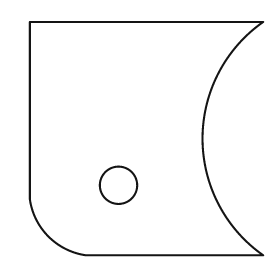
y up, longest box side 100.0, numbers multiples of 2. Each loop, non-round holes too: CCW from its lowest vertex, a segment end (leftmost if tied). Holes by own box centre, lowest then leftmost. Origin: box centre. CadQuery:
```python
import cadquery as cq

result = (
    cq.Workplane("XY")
    .moveTo(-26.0, -50.0)
    .lineTo(50.0, -50.0)
    .threePointArc((24.0, 0.0), (50.0, 50.0))
    .lineTo(-50.0, 50.0)
    .lineTo(-50.0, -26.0)
    .threePointArc((-42.0, -42.0), (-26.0, -50.0))
    .close()
    .moveTo(-12.0, -20.0)
    .circle(8.0)
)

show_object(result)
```